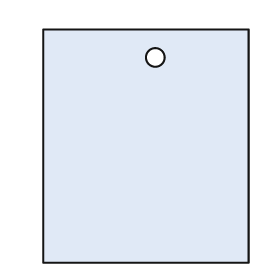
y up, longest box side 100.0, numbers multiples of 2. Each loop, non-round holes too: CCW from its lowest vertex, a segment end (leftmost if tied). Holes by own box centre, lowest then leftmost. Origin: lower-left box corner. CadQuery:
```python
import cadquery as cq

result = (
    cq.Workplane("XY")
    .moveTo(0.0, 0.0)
    .lineTo(88.0, 0.0)
    .lineTo(88.0, 100.0)
    .lineTo(0.0, 100.0)
    .close()
    .moveTo(48.0, 88.0)
    .circle(4.0)
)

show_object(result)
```